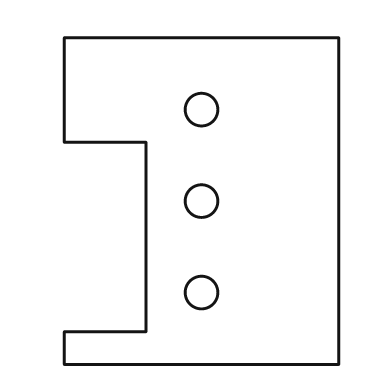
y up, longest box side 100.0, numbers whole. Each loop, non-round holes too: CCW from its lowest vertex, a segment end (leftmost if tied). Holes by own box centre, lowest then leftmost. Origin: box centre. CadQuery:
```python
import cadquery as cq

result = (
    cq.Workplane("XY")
    .moveTo(-42.0, -50.0)
    .lineTo(42.0, -50.0)
    .lineTo(42.0, 50.0)
    .lineTo(-42.0, 50.0)
    .lineTo(-42.0, 18.0)
    .lineTo(-17.0, 18.0)
    .lineTo(-17.0, -40.0)
    .lineTo(-42.0, -40.0)
    .close()
    .moveTo(0.0, -28.0)
    .circle(5.0)
    .moveTo(0.0, 0.0)
    .circle(5.0)
    .moveTo(0.0, 28.0)
    .circle(5.0)
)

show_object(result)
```